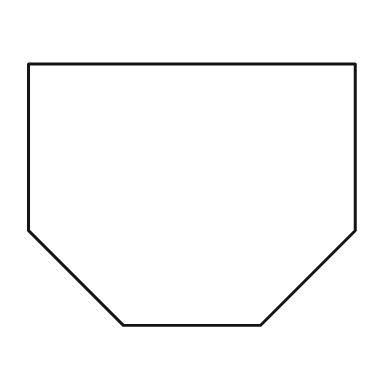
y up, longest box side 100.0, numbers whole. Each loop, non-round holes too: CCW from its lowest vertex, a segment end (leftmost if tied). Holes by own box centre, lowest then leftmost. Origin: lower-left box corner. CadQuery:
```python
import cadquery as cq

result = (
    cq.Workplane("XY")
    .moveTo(29.0, 0.0)
    .lineTo(71.0, 0.0)
    .lineTo(100.0, 29.0)
    .lineTo(100.0, 80.0)
    .lineTo(0.0, 80.0)
    .lineTo(0.0, 29.0)
    .close()
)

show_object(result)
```